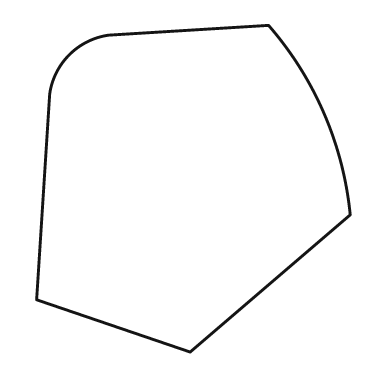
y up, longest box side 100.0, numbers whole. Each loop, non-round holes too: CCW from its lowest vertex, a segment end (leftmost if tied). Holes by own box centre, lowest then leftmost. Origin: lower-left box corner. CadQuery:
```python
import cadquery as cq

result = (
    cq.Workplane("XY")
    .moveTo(47.0, 0.0)
    .lineTo(96.0, 42.0)
    .threePointArc((88.0, 73.0), (71.0, 100.0))
    .lineTo(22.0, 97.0)
    .threePointArc((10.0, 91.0), (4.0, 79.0))
    .lineTo(0.0, 16.0)
    .close()
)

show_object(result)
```